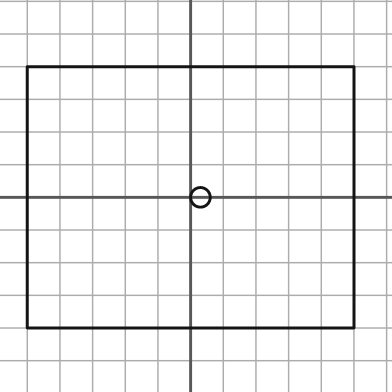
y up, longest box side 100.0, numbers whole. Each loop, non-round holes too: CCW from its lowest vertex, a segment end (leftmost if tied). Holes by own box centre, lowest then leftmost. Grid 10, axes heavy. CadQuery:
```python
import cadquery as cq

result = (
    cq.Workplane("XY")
    .moveTo(-50.0, -40.0)
    .lineTo(50.0, -40.0)
    .lineTo(50.0, 40.0)
    .lineTo(-50.0, 40.0)
    .close()
    .moveTo(3.0, 0.0)
    .circle(3.0)
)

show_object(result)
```